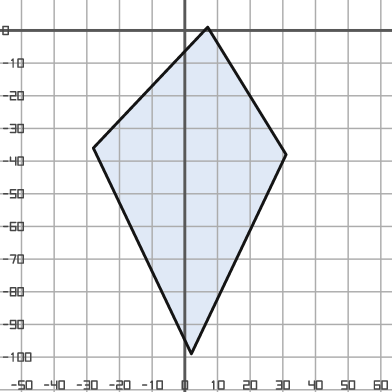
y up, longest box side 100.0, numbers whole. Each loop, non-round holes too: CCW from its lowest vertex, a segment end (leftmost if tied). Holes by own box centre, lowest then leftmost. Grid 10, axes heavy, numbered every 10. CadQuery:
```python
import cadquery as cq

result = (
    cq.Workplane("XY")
    .moveTo(2.0, -99.0)
    .lineTo(31.0, -38.0)
    .lineTo(7.0, 1.0)
    .lineTo(-28.0, -36.0)
    .close()
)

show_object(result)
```